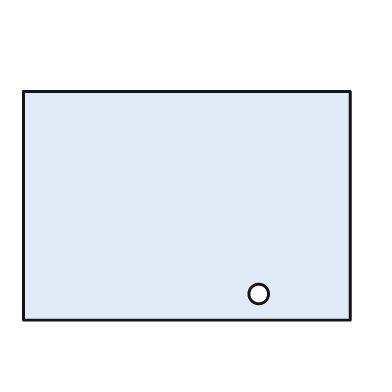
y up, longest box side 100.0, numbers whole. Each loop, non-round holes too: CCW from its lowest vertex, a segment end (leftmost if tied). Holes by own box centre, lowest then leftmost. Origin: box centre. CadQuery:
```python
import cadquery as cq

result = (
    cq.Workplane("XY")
    .moveTo(-50.0, -35.0)
    .lineTo(50.0, -35.0)
    .lineTo(50.0, 35.0)
    .lineTo(-50.0, 35.0)
    .close()
    .moveTo(22.0, -27.0)
    .circle(3.0)
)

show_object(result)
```